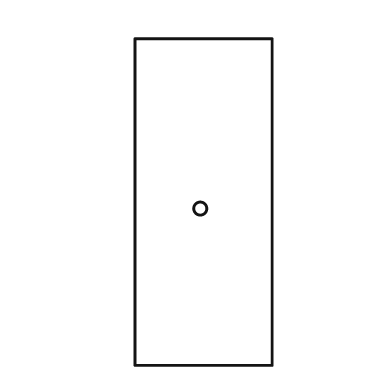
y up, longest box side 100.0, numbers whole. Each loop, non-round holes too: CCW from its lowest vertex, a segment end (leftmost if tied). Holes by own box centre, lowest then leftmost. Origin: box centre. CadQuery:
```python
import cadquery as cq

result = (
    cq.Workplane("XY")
    .moveTo(-21.0, -50.0)
    .lineTo(21.0, -50.0)
    .lineTo(21.0, 50.0)
    .lineTo(-21.0, 50.0)
    .close()
    .moveTo(-1.0, -2.0)
    .circle(2.0)
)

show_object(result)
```